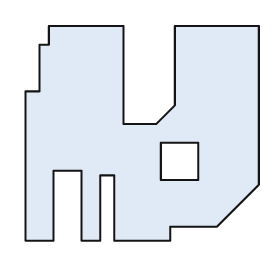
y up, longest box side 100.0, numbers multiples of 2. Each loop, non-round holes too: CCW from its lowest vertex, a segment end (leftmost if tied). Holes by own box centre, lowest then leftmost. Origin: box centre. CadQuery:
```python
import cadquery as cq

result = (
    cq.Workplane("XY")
    .moveTo(-50.0, -46.0)
    .lineTo(-38.0, -46.0)
    .lineTo(-38.0, -16.0)
    .lineTo(-26.0, -16.0)
    .lineTo(-26.0, -46.0)
    .lineTo(-18.0, -46.0)
    .lineTo(-18.0, -18.0)
    .lineTo(-12.0, -18.0)
    .lineTo(-12.0, -46.0)
    .lineTo(12.0, -46.0)
    .lineTo(12.0, -40.0)
    .lineTo(32.0, -40.0)
    .lineTo(50.0, -22.0)
    .lineTo(50.0, 46.0)
    .lineTo(14.0, 46.0)
    .lineTo(14.0, 12.0)
    .lineTo(6.0, 4.0)
    .lineTo(-8.0, 4.0)
    .lineTo(-8.0, 46.0)
    .lineTo(-40.0, 46.0)
    .lineTo(-40.0, 38.0)
    .lineTo(-44.0, 38.0)
    .lineTo(-44.0, 18.0)
    .lineTo(-50.0, 18.0)
    .close()
    .moveTo(8.0, -20.0)
    .lineTo(24.0, -20.0)
    .lineTo(24.0, -4.0)
    .lineTo(8.0, -4.0)
    .close()
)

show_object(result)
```